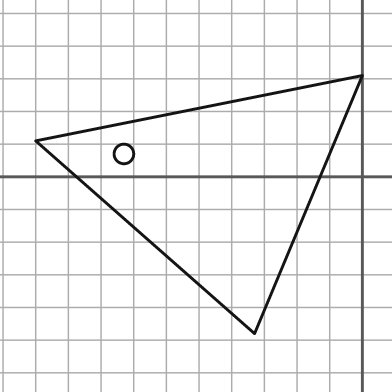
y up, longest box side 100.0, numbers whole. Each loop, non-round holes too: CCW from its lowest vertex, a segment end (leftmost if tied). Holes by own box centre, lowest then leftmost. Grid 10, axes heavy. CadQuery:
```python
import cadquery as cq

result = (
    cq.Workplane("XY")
    .moveTo(-33.0, -48.0)
    .lineTo(0.0, 31.0)
    .lineTo(-100.0, 11.0)
    .close()
    .moveTo(-73.0, 7.0)
    .circle(3.0)
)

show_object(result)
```